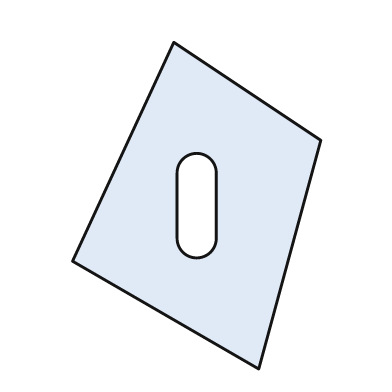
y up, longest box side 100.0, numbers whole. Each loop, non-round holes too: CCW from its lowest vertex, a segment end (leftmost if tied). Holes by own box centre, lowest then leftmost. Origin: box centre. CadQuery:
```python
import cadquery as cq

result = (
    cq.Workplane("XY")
    .moveTo(19.0, -50.0)
    .lineTo(38.0, 20.0)
    .lineTo(-7.0, 50.0)
    .lineTo(-38.0, -17.0)
    .close()
    .moveTo(-6.0, -10.0)
    .threePointArc((0.0, -16.0), (6.0, -10.0))
    .lineTo(6.0, 10.0)
    .threePointArc((0.0, 16.0), (-6.0, 10.0))
    .close()
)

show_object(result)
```